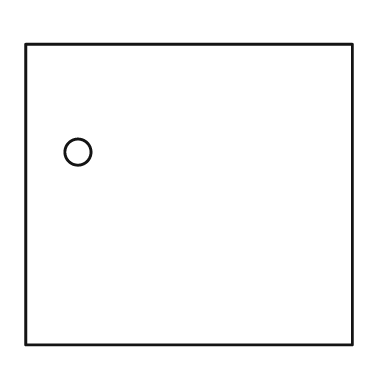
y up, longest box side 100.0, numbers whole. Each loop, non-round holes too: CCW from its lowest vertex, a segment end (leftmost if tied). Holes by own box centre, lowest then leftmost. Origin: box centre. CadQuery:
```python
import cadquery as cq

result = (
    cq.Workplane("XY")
    .moveTo(-50.0, -46.0)
    .lineTo(50.0, -46.0)
    .lineTo(50.0, 46.0)
    .lineTo(-50.0, 46.0)
    .close()
    .moveTo(-34.0, 13.0)
    .circle(4.0)
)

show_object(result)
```